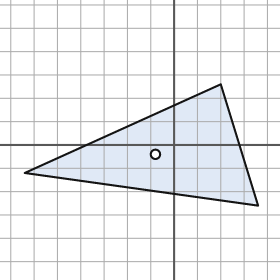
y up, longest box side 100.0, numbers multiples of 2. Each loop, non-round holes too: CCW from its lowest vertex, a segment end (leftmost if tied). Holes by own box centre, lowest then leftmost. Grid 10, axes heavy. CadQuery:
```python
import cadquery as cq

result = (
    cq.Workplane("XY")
    .moveTo(36.0, -26.0)
    .lineTo(20.0, 26.0)
    .lineTo(-64.0, -12.0)
    .close()
    .moveTo(-8.0, -4.0)
    .circle(2.0)
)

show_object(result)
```